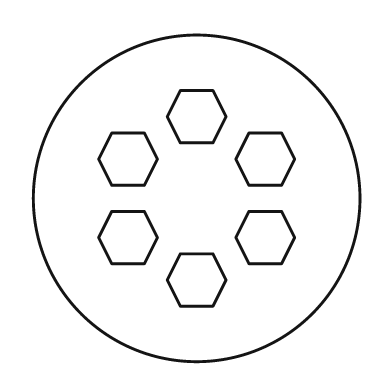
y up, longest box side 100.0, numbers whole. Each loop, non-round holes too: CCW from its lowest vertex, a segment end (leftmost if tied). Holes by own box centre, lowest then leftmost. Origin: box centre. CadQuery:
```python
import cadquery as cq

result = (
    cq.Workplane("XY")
    .moveTo(0.0, 0.0)
    .circle(50.0)
    .moveTo(-5.0, -33.0)
    .lineTo(5.0, -33.0)
    .lineTo(9.0, -25.0)
    .lineTo(5.0, -17.0)
    .lineTo(-5.0, -17.0)
    .lineTo(-9.0, -25.0)
    .close()
    .moveTo(-26.0, -20.0)
    .lineTo(-16.0, -20.0)
    .lineTo(-12.0, -12.0)
    .lineTo(-16.0, -4.0)
    .lineTo(-26.0, -4.0)
    .lineTo(-30.0, -12.0)
    .close()
    .moveTo(16.0, -20.0)
    .lineTo(26.0, -20.0)
    .lineTo(30.0, -12.0)
    .lineTo(26.0, -4.0)
    .lineTo(16.0, -4.0)
    .lineTo(12.0, -12.0)
    .close()
    .moveTo(-26.0, 4.0)
    .lineTo(-16.0, 4.0)
    .lineTo(-12.0, 12.0)
    .lineTo(-16.0, 20.0)
    .lineTo(-26.0, 20.0)
    .lineTo(-30.0, 12.0)
    .close()
    .moveTo(16.0, 4.0)
    .lineTo(26.0, 4.0)
    .lineTo(30.0, 12.0)
    .lineTo(26.0, 20.0)
    .lineTo(16.0, 20.0)
    .lineTo(12.0, 12.0)
    .close()
    .moveTo(-5.0, 17.0)
    .lineTo(5.0, 17.0)
    .lineTo(9.0, 25.0)
    .lineTo(5.0, 33.0)
    .lineTo(-5.0, 33.0)
    .lineTo(-9.0, 25.0)
    .close()
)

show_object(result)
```